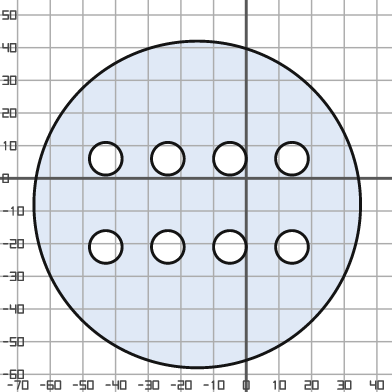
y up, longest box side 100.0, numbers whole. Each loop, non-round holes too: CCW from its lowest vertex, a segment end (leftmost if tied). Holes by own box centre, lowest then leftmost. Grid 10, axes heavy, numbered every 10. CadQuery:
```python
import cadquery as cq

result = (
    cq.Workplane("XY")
    .moveTo(-15.0, -8.0)
    .circle(50.0)
    .moveTo(-43.0, -21.0)
    .circle(5.0)
    .moveTo(-24.0, -21.0)
    .circle(5.0)
    .moveTo(-5.0, -21.0)
    .circle(5.0)
    .moveTo(14.0, -21.0)
    .circle(5.0)
    .moveTo(-43.0, 6.0)
    .circle(5.0)
    .moveTo(-24.0, 6.0)
    .circle(5.0)
    .moveTo(-5.0, 6.0)
    .circle(5.0)
    .moveTo(14.0, 6.0)
    .circle(5.0)
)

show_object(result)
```